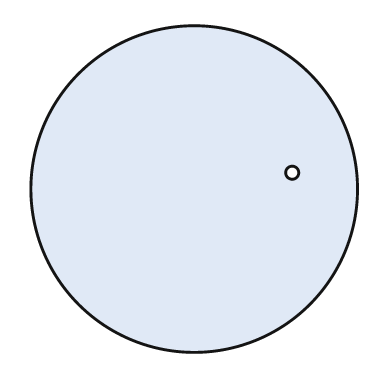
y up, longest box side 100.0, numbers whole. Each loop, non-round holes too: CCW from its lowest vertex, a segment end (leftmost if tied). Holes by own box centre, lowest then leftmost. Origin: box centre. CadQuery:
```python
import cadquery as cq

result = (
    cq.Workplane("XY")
    .moveTo(0.0, 0.0)
    .circle(50.0)
    .moveTo(30.0, 5.0)
    .circle(2.0)
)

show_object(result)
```